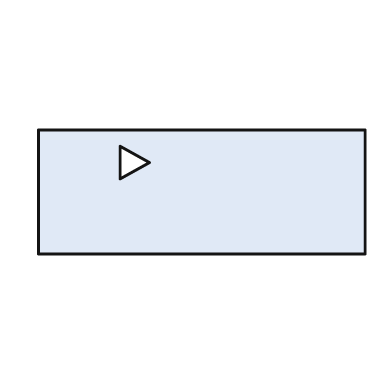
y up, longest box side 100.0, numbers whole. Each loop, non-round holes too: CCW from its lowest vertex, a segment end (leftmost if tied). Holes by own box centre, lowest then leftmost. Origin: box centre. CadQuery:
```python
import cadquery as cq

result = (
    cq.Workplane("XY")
    .moveTo(-50.0, -19.0)
    .lineTo(50.0, -19.0)
    .lineTo(50.0, 19.0)
    .lineTo(-50.0, 19.0)
    .close()
    .moveTo(-25.0, 4.0)
    .lineTo(-16.0, 9.0)
    .lineTo(-25.0, 14.0)
    .close()
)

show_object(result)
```